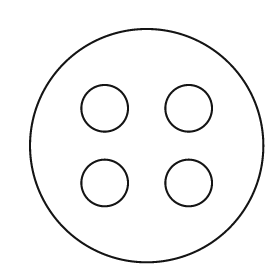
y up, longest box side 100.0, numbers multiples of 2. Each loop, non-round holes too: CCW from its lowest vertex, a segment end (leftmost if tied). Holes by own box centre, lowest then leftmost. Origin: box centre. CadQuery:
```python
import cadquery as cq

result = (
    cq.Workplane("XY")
    .moveTo(0.0, 0.0)
    .circle(50.0)
    .moveTo(-18.0, -16.0)
    .circle(10.0)
    .moveTo(18.0, -16.0)
    .circle(10.0)
    .moveTo(-18.0, 16.0)
    .circle(10.0)
    .moveTo(18.0, 16.0)
    .circle(10.0)
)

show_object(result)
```